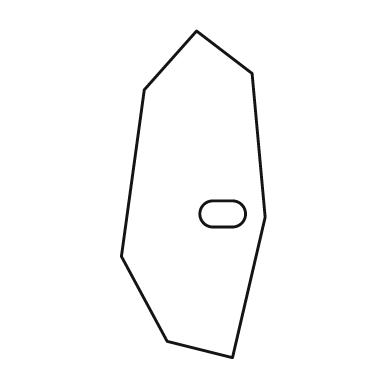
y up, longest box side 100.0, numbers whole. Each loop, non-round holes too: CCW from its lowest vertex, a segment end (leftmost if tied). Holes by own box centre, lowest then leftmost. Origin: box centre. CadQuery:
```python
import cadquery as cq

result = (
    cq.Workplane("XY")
    .moveTo(12.0, -50.0)
    .lineTo(22.0, -7.0)
    .lineTo(18.0, 37.0)
    .lineTo(1.0, 50.0)
    .lineTo(-15.0, 32.0)
    .lineTo(-22.0, -19.0)
    .lineTo(-8.0, -45.0)
    .close()
    .moveTo(6.0, -10.0)
    .lineTo(12.0, -10.0)
    .threePointArc((16.0, -6.0), (12.0, -2.0))
    .lineTo(6.0, -2.0)
    .threePointArc((2.0, -6.0), (6.0, -10.0))
    .close()
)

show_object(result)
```